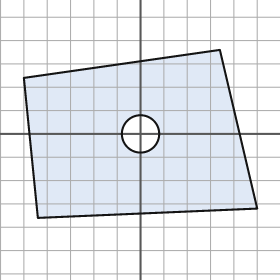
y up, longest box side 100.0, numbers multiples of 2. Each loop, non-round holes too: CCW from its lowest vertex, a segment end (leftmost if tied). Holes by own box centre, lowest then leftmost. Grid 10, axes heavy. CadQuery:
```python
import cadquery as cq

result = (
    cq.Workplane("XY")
    .moveTo(-44.0, -36.0)
    .lineTo(50.0, -32.0)
    .lineTo(34.0, 36.0)
    .lineTo(-50.0, 24.0)
    .close()
    .moveTo(0.0, 0.0)
    .circle(8.0)
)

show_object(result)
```